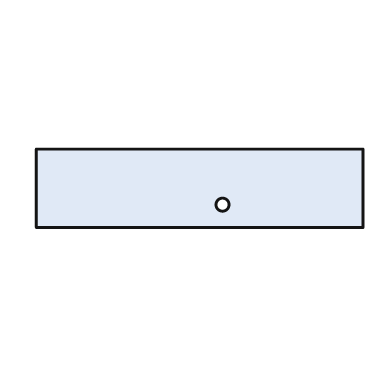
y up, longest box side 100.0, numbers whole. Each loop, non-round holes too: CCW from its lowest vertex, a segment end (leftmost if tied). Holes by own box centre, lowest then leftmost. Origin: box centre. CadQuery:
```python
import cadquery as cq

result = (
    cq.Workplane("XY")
    .moveTo(-50.0, -12.0)
    .lineTo(50.0, -12.0)
    .lineTo(50.0, 12.0)
    .lineTo(-50.0, 12.0)
    .close()
    .moveTo(7.0, -5.0)
    .circle(2.0)
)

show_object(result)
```